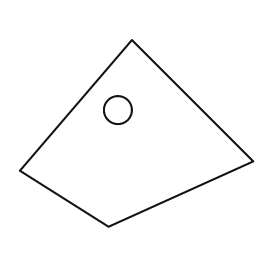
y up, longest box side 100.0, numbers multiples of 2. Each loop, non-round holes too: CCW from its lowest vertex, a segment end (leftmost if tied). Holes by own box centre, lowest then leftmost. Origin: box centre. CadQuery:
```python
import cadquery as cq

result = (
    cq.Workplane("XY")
    .moveTo(-12.0, -40.0)
    .lineTo(50.0, -12.0)
    .lineTo(-2.0, 40.0)
    .lineTo(-50.0, -16.0)
    .close()
    .moveTo(-8.0, 10.0)
    .circle(6.0)
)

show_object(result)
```